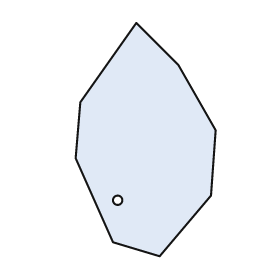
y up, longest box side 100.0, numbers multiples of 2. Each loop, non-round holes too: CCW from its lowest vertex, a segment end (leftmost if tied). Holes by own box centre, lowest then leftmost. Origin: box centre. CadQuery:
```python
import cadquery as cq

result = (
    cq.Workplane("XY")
    .moveTo(6.0, -50.0)
    .lineTo(28.0, -24.0)
    .lineTo(30.0, 4.0)
    .lineTo(14.0, 32.0)
    .lineTo(-4.0, 50.0)
    .lineTo(-28.0, 16.0)
    .lineTo(-30.0, -8.0)
    .lineTo(-14.0, -44.0)
    .close()
    .moveTo(-12.0, -26.0)
    .circle(2.0)
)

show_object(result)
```